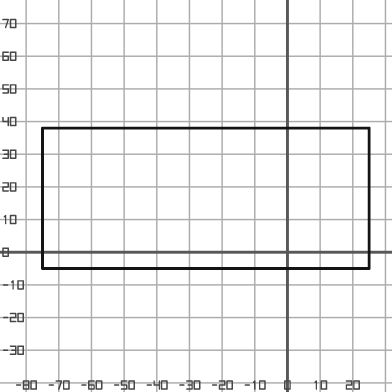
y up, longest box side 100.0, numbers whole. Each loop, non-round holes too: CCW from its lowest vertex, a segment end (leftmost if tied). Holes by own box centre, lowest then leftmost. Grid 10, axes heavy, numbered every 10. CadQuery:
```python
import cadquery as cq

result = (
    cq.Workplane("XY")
    .moveTo(-75.0, -5.0)
    .lineTo(25.0, -5.0)
    .lineTo(25.0, 38.0)
    .lineTo(-75.0, 38.0)
    .close()
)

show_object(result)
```